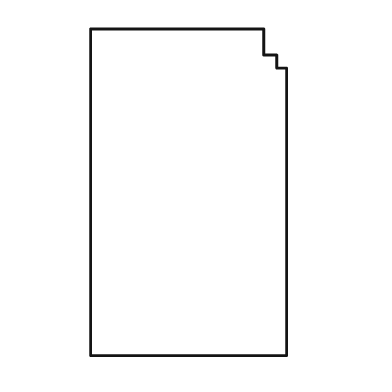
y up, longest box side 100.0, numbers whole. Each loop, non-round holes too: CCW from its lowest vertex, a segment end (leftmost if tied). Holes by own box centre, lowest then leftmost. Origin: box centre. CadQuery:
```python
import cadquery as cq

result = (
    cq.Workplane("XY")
    .moveTo(-30.0, -50.0)
    .lineTo(30.0, -50.0)
    .lineTo(30.0, 38.0)
    .lineTo(27.0, 38.0)
    .lineTo(27.0, 42.0)
    .lineTo(23.0, 42.0)
    .lineTo(23.0, 50.0)
    .lineTo(-30.0, 50.0)
    .close()
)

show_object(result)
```